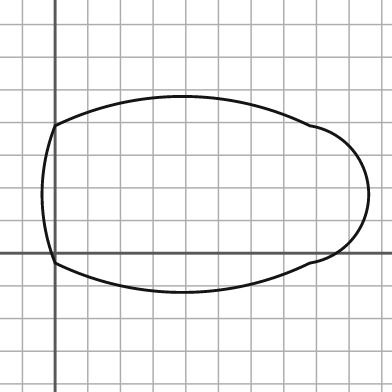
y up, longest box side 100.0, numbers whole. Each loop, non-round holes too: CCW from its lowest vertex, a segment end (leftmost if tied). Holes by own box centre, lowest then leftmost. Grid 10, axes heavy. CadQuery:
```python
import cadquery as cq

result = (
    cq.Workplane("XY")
    .moveTo(0.0, -3.0)
    .threePointArc((39.0, -12.0), (78.0, -3.0))
    .threePointArc((96.0, 18.0), (78.0, 39.0))
    .threePointArc((39.0, 48.0), (0.0, 39.0))
    .threePointArc((-4.0, 18.0), (0.0, -3.0))
    .close()
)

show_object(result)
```